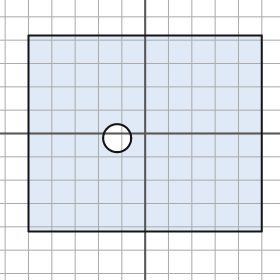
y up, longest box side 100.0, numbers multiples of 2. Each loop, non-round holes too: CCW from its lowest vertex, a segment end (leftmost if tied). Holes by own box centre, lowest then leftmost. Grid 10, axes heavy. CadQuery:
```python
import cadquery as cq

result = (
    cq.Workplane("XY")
    .moveTo(-50.0, -42.0)
    .lineTo(50.0, -42.0)
    .lineTo(50.0, 42.0)
    .lineTo(-50.0, 42.0)
    .close()
    .moveTo(-12.0, -2.0)
    .circle(6.0)
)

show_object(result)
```